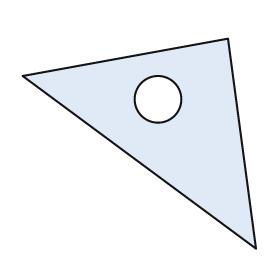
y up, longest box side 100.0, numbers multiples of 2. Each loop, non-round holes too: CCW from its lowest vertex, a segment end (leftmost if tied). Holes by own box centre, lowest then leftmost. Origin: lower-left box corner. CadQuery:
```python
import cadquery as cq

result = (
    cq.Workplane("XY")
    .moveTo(100.0, 0.0)
    .lineTo(88.0, 90.0)
    .lineTo(0.0, 74.0)
    .close()
    .moveTo(58.0, 64.0)
    .circle(10.0)
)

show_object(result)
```